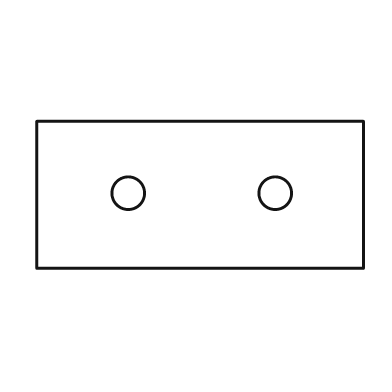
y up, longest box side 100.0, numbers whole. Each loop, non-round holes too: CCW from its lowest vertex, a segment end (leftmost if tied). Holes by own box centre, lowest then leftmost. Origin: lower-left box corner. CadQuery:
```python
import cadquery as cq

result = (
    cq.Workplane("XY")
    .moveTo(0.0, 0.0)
    .lineTo(100.0, 0.0)
    .lineTo(100.0, 45.0)
    .lineTo(0.0, 45.0)
    .close()
    .moveTo(28.0, 23.0)
    .circle(5.0)
    .moveTo(73.0, 23.0)
    .circle(5.0)
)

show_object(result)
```